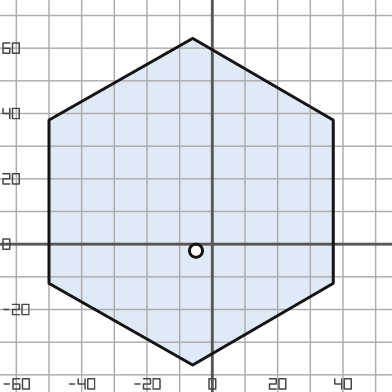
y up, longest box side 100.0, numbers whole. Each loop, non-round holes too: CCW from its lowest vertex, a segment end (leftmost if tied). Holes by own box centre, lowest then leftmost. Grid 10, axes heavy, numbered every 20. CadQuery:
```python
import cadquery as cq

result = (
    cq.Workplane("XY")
    .moveTo(-6.0, -37.0)
    .lineTo(37.0, -12.0)
    .lineTo(37.0, 38.0)
    .lineTo(-6.0, 63.0)
    .lineTo(-50.0, 38.0)
    .lineTo(-50.0, -12.0)
    .close()
    .moveTo(-5.0, -2.0)
    .circle(2.0)
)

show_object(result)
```